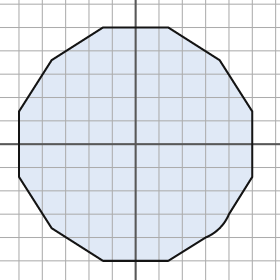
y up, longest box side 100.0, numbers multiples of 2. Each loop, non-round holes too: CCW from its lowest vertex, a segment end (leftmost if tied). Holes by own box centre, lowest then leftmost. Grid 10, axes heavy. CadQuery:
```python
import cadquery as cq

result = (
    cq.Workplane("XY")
    .moveTo(-14.0, -50.0)
    .lineTo(14.0, -50.0)
    .lineTo(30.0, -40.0)
    .threePointArc((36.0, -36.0), (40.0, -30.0))
    .lineTo(50.0, -14.0)
    .lineTo(50.0, 14.0)
    .lineTo(36.0, 36.0)
    .lineTo(14.0, 50.0)
    .lineTo(-14.0, 50.0)
    .lineTo(-36.0, 36.0)
    .lineTo(-50.0, 14.0)
    .lineTo(-50.0, -14.0)
    .lineTo(-36.0, -36.0)
    .close()
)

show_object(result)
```